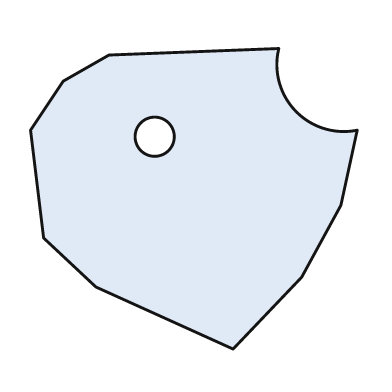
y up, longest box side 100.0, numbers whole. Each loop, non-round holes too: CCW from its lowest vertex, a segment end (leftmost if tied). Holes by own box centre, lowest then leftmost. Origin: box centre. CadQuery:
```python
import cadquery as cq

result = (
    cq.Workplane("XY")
    .moveTo(12.0, -46.0)
    .lineTo(33.0, -24.0)
    .lineTo(45.0, -2.0)
    .lineTo(50.0, 21.0)
    .threePointArc((31.0, 27.0), (26.0, 46.0))
    .lineTo(-26.0, 44.0)
    .lineTo(-40.0, 36.0)
    .lineTo(-50.0, 21.0)
    .lineTo(-46.0, -12.0)
    .lineTo(-30.0, -27.0)
    .close()
    .moveTo(-12.0, 19.0)
    .circle(6.0)
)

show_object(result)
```